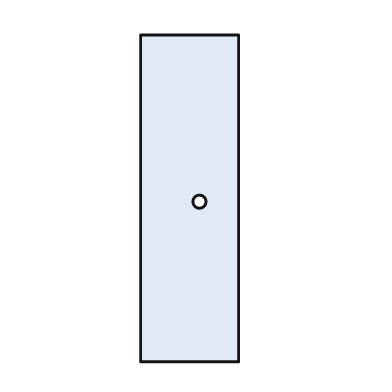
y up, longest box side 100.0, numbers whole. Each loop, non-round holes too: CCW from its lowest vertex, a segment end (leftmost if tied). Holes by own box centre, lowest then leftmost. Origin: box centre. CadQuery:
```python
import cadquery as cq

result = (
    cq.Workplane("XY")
    .moveTo(-15.0, -50.0)
    .lineTo(15.0, -50.0)
    .lineTo(15.0, 50.0)
    .lineTo(-15.0, 50.0)
    .close()
    .moveTo(3.0, -1.0)
    .circle(2.0)
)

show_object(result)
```